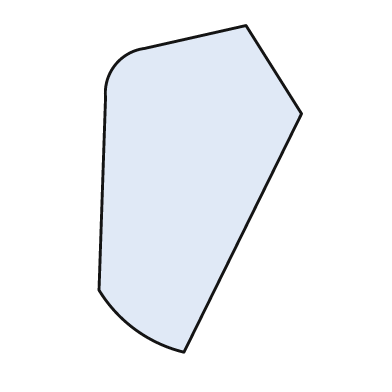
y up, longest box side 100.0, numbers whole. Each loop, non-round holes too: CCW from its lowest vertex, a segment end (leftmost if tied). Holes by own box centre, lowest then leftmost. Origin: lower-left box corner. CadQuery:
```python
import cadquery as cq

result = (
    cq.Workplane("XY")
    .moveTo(26.0, 0.0)
    .lineTo(62.0, 73.0)
    .lineTo(45.0, 100.0)
    .lineTo(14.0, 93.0)
    .threePointArc((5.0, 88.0), (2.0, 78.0))
    .lineTo(0.0, 19.0)
    .threePointArc((11.0, 7.0), (26.0, 0.0))
    .close()
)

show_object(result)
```